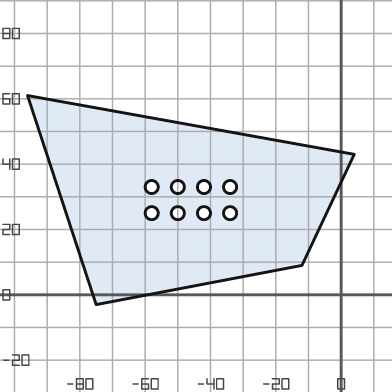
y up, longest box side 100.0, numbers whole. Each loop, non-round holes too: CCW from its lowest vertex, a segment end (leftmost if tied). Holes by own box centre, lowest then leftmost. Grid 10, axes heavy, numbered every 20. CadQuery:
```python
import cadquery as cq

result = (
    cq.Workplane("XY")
    .moveTo(-75.0, -3.0)
    .lineTo(-12.0, 9.0)
    .lineTo(4.0, 43.0)
    .lineTo(-96.0, 61.0)
    .close()
    .moveTo(-58.0, 25.0)
    .circle(2.0)
    .moveTo(-50.0, 25.0)
    .circle(2.0)
    .moveTo(-42.0, 25.0)
    .circle(2.0)
    .moveTo(-34.0, 25.0)
    .circle(2.0)
    .moveTo(-58.0, 33.0)
    .circle(2.0)
    .moveTo(-50.0, 33.0)
    .circle(2.0)
    .moveTo(-42.0, 33.0)
    .circle(2.0)
    .moveTo(-34.0, 33.0)
    .circle(2.0)
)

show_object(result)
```